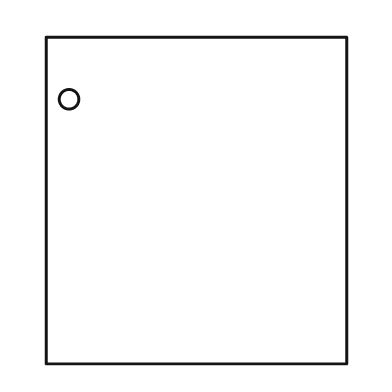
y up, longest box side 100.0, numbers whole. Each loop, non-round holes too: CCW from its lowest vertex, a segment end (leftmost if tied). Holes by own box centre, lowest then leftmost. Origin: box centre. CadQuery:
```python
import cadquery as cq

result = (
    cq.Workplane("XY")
    .moveTo(-46.0, -50.0)
    .lineTo(46.0, -50.0)
    .lineTo(46.0, 50.0)
    .lineTo(-46.0, 50.0)
    .close()
    .moveTo(-39.0, 31.0)
    .circle(3.0)
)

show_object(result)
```